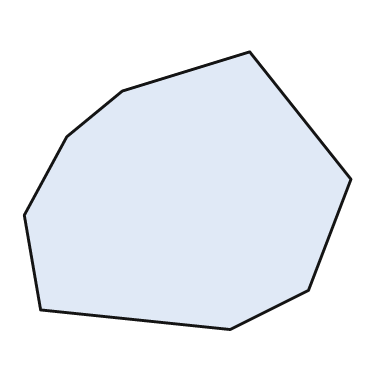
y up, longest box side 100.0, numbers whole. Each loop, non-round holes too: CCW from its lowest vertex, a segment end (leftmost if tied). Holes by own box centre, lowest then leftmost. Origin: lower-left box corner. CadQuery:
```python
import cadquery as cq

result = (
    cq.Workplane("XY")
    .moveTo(63.0, 0.0)
    .lineTo(87.0, 12.0)
    .lineTo(100.0, 46.0)
    .lineTo(69.0, 85.0)
    .lineTo(30.0, 73.0)
    .lineTo(13.0, 59.0)
    .lineTo(0.0, 35.0)
    .lineTo(5.0, 6.0)
    .close()
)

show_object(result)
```